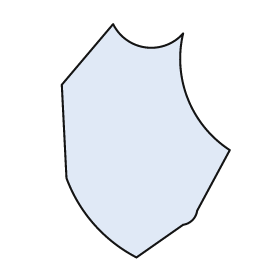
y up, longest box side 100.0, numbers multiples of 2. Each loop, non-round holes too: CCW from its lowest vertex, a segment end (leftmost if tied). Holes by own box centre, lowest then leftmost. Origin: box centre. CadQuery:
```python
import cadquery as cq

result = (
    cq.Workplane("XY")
    .moveTo(-4.0, -50.0)
    .lineTo(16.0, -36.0)
    .threePointArc((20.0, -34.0), (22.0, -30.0))
    .lineTo(36.0, -4.0)
    .threePointArc((18.0, 18.0), (16.0, 46.0))
    .threePointArc((0.0, 40.0), (-14.0, 50.0))
    .lineTo(-36.0, 24.0)
    .lineTo(-34.0, -16.0)
    .threePointArc((-22.0, -36.0), (-4.0, -50.0))
    .close()
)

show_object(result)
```